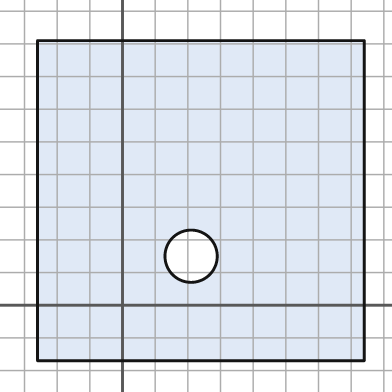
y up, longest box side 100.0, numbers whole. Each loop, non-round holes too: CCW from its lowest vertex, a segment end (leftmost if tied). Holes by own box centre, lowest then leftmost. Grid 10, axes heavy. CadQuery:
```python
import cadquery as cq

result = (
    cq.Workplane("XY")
    .moveTo(-26.0, -17.0)
    .lineTo(74.0, -17.0)
    .lineTo(74.0, 81.0)
    .lineTo(-26.0, 81.0)
    .close()
    .moveTo(21.0, 15.0)
    .circle(8.0)
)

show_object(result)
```